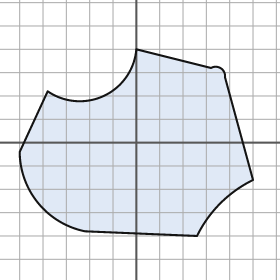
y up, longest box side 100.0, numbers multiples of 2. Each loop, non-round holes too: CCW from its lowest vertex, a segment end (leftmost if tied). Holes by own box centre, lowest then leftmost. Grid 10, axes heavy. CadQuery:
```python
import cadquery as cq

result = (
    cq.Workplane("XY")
    .moveTo(26.0, -40.0)
    .threePointArc((36.0, -26.0), (50.0, -16.0))
    .lineTo(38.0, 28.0)
    .threePointArc((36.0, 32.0), (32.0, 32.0))
    .lineTo(0.0, 40.0)
    .threePointArc((-14.0, 20.0), (-38.0, 22.0))
    .lineTo(-50.0, -4.0)
    .threePointArc((-42.0, -26.0), (-22.0, -38.0))
    .close()
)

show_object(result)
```